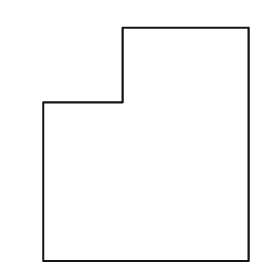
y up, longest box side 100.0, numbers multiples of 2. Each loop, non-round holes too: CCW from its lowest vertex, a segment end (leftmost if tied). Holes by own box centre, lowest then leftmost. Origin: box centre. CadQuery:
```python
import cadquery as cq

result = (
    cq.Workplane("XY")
    .moveTo(-44.0, -50.0)
    .lineTo(44.0, -50.0)
    .lineTo(44.0, 50.0)
    .lineTo(-10.0, 50.0)
    .lineTo(-10.0, 18.0)
    .lineTo(-44.0, 18.0)
    .close()
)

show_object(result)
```